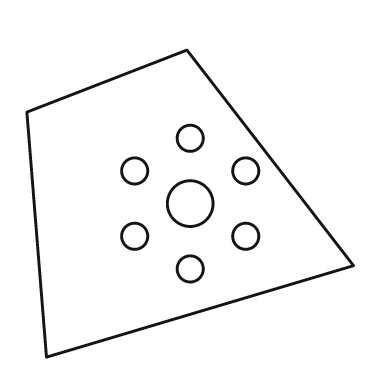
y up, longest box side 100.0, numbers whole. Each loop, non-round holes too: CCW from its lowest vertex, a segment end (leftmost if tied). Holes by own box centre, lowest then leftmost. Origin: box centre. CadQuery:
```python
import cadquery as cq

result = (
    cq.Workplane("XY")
    .moveTo(-44.0, -47.0)
    .lineTo(50.0, -19.0)
    .lineTo(-1.0, 47.0)
    .lineTo(-50.0, 28.0)
    .close()
    .moveTo(0.0, -20.0)
    .circle(4.0)
    .moveTo(-17.0, -10.0)
    .circle(4.0)
    .moveTo(17.0, -10.0)
    .circle(4.0)
    .moveTo(0.0, 0.0)
    .circle(7.0)
    .moveTo(-17.0, 10.0)
    .circle(4.0)
    .moveTo(17.0, 10.0)
    .circle(4.0)
    .moveTo(0.0, 20.0)
    .circle(4.0)
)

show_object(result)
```